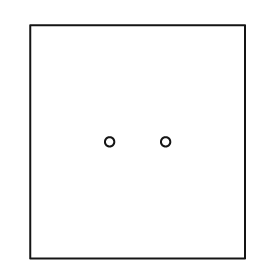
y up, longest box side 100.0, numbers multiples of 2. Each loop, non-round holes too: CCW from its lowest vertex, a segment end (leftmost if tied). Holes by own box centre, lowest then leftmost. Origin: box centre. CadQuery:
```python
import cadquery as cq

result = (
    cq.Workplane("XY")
    .moveTo(-46.0, -50.0)
    .lineTo(46.0, -50.0)
    .lineTo(46.0, 50.0)
    .lineTo(-46.0, 50.0)
    .close()
    .moveTo(-12.0, 0.0)
    .circle(2.0)
    .moveTo(12.0, 0.0)
    .circle(2.0)
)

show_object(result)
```